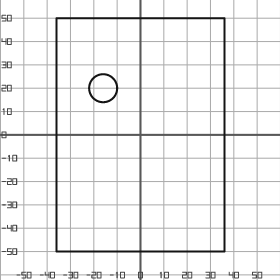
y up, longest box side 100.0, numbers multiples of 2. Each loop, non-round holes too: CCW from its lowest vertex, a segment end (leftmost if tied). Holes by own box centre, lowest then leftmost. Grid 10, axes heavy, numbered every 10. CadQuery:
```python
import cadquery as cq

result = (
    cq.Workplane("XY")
    .moveTo(-36.0, -50.0)
    .lineTo(36.0, -50.0)
    .lineTo(36.0, 50.0)
    .lineTo(-36.0, 50.0)
    .close()
    .moveTo(-16.0, 20.0)
    .circle(6.0)
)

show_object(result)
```